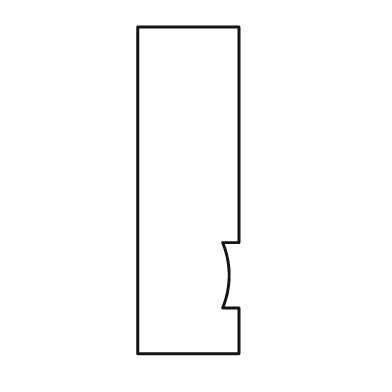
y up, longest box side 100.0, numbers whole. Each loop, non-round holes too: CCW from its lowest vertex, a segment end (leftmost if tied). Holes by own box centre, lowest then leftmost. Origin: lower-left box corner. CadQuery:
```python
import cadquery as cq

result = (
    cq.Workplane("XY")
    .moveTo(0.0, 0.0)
    .lineTo(31.0, 0.0)
    .lineTo(31.0, 14.0)
    .lineTo(26.0, 14.0)
    .threePointArc((28.0, 24.0), (26.0, 34.0))
    .lineTo(31.0, 34.0)
    .lineTo(31.0, 100.0)
    .lineTo(0.0, 100.0)
    .close()
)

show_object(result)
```